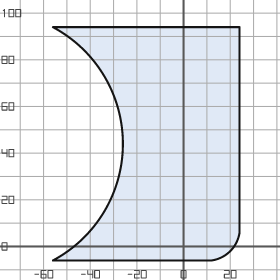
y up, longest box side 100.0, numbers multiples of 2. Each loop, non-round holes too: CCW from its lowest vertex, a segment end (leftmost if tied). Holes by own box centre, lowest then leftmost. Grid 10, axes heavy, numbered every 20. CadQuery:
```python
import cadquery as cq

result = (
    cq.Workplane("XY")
    .moveTo(-56.0, -6.0)
    .lineTo(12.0, -6.0)
    .threePointArc((20.0, -2.0), (24.0, 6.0))
    .lineTo(24.0, 94.0)
    .lineTo(-56.0, 94.0)
    .threePointArc((-26.0, 44.0), (-56.0, -6.0))
    .close()
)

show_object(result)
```